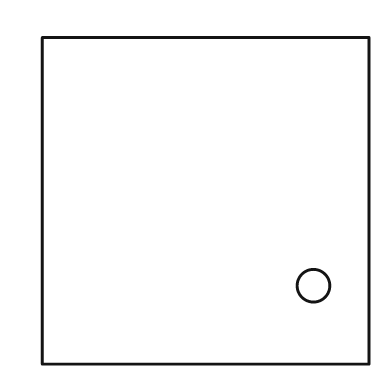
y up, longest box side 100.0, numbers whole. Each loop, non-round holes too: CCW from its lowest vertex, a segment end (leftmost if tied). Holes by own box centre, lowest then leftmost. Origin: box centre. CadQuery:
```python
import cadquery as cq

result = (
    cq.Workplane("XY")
    .moveTo(-50.0, -50.0)
    .lineTo(50.0, -50.0)
    .lineTo(50.0, 50.0)
    .lineTo(-50.0, 50.0)
    .close()
    .moveTo(33.0, -26.0)
    .circle(5.0)
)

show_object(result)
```